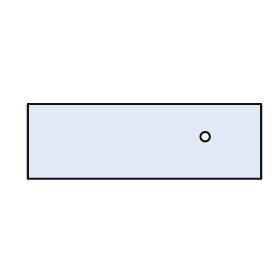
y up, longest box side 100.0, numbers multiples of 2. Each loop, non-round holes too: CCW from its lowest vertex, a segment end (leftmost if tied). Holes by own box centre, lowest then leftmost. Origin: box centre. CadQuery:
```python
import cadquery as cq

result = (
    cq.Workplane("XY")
    .moveTo(-50.0, -16.0)
    .lineTo(50.0, -16.0)
    .lineTo(50.0, 16.0)
    .lineTo(-50.0, 16.0)
    .close()
    .moveTo(26.0, 2.0)
    .circle(2.0)
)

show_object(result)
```